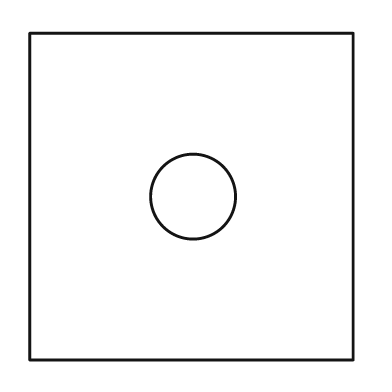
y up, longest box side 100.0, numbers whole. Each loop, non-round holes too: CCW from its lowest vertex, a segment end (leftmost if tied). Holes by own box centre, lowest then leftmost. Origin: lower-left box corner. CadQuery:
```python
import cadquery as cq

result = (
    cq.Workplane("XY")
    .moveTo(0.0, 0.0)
    .lineTo(99.0, 0.0)
    .lineTo(99.0, 100.0)
    .lineTo(0.0, 100.0)
    .close()
    .moveTo(50.0, 50.0)
    .circle(13.0)
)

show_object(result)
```